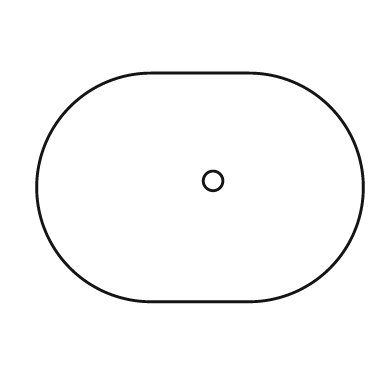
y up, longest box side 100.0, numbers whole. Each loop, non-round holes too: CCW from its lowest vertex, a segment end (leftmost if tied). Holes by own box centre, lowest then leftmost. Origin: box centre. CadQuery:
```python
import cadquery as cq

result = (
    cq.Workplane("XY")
    .moveTo(-15.0, -35.0)
    .lineTo(15.0, -35.0)
    .threePointArc((50.0, 0.0), (15.0, 35.0))
    .lineTo(-15.0, 35.0)
    .threePointArc((-50.0, 0.0), (-15.0, -35.0))
    .close()
    .moveTo(4.0, 2.0)
    .circle(3.0)
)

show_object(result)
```